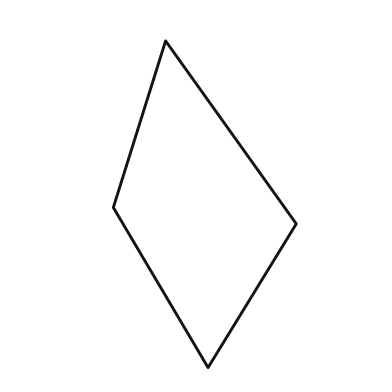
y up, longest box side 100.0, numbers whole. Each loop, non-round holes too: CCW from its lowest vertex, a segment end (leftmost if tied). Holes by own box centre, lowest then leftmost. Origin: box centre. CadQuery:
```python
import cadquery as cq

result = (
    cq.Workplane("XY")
    .moveTo(1.0, -50.0)
    .lineTo(28.0, -6.0)
    .lineTo(-12.0, 50.0)
    .lineTo(-28.0, -1.0)
    .close()
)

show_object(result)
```